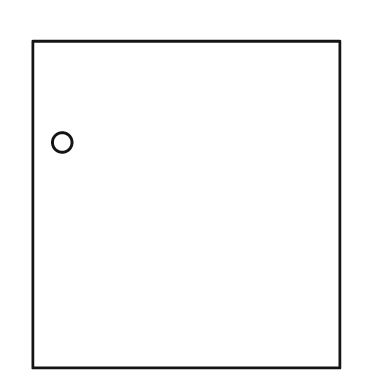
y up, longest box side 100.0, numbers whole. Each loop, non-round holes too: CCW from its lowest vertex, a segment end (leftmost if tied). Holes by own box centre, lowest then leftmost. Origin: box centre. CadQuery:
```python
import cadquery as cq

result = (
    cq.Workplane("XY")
    .moveTo(-47.0, -50.0)
    .lineTo(47.0, -50.0)
    .lineTo(47.0, 50.0)
    .lineTo(-47.0, 50.0)
    .close()
    .moveTo(-38.0, 19.0)
    .circle(3.0)
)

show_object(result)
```